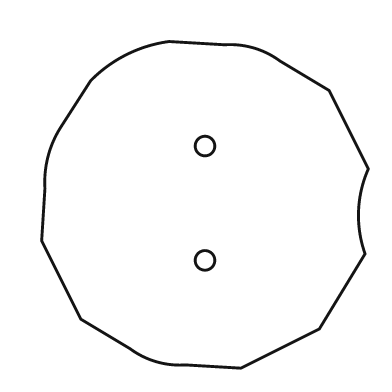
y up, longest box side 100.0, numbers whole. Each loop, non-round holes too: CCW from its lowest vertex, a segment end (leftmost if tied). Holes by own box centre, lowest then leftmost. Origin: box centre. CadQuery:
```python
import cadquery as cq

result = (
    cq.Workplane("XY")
    .moveTo(11.0, -50.0)
    .lineTo(35.0, -38.0)
    .lineTo(49.0, -15.0)
    .threePointArc((47.0, -2.0), (50.0, 11.0))
    .lineTo(38.0, 35.0)
    .lineTo(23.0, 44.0)
    .threePointArc((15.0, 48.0), (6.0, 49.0))
    .lineTo(-11.0, 50.0)
    .threePointArc((-24.0, 46.0), (-35.0, 38.0))
    .lineTo(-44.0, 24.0)
    .threePointArc((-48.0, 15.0), (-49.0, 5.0))
    .lineTo(-50.0, -11.0)
    .lineTo(-38.0, -35.0)
    .lineTo(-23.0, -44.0)
    .threePointArc((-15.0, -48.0), (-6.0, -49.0))
    .close()
    .moveTo(0.0, -17.0)
    .circle(3.0)
    .moveTo(0.0, 18.0)
    .circle(3.0)
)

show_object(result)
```